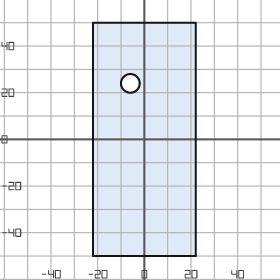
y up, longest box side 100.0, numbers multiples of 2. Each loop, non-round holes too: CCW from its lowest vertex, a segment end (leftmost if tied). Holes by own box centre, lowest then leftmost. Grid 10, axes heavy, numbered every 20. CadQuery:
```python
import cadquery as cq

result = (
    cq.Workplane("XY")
    .moveTo(-22.0, -50.0)
    .lineTo(22.0, -50.0)
    .lineTo(22.0, 50.0)
    .lineTo(-22.0, 50.0)
    .close()
    .moveTo(-6.0, 24.0)
    .circle(4.0)
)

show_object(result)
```